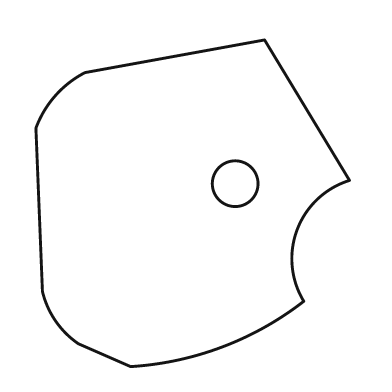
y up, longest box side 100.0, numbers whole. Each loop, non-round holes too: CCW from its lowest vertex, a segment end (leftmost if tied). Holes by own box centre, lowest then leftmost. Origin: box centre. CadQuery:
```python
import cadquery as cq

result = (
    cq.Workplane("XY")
    .moveTo(-19.0, -50.0)
    .threePointArc((9.0, -44.0), (34.0, -30.0))
    .threePointArc((32.0, -8.0), (48.0, 7.0))
    .lineTo(22.0, 50.0)
    .lineTo(-33.0, 40.0)
    .threePointArc((-42.0, 33.0), (-48.0, 23.0))
    .lineTo(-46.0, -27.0)
    .threePointArc((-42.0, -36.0), (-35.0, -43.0))
    .close()
    .moveTo(13.0, 6.0)
    .circle(7.0)
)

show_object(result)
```